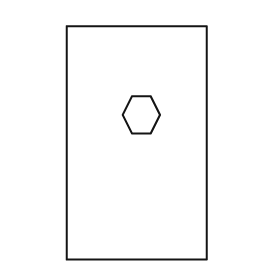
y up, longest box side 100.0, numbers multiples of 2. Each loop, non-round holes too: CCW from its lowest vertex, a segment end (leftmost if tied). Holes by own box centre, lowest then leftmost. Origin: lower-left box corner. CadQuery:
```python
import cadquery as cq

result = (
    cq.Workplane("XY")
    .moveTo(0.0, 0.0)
    .lineTo(60.0, 0.0)
    .lineTo(60.0, 100.0)
    .lineTo(0.0, 100.0)
    .close()
    .moveTo(28.0, 54.0)
    .lineTo(36.0, 54.0)
    .lineTo(40.0, 62.0)
    .lineTo(36.0, 70.0)
    .lineTo(28.0, 70.0)
    .lineTo(24.0, 62.0)
    .close()
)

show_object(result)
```